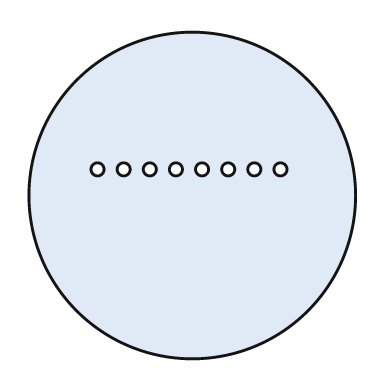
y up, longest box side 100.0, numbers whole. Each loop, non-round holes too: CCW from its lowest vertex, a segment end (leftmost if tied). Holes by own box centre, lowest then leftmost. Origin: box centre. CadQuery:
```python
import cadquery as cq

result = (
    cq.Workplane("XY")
    .moveTo(0.0, 0.0)
    .circle(50.0)
    .moveTo(-29.0, 8.0)
    .circle(2.0)
    .moveTo(-21.0, 8.0)
    .circle(2.0)
    .moveTo(-13.0, 8.0)
    .circle(2.0)
    .moveTo(-5.0, 8.0)
    .circle(2.0)
    .moveTo(3.0, 8.0)
    .circle(2.0)
    .moveTo(11.0, 8.0)
    .circle(2.0)
    .moveTo(19.0, 8.0)
    .circle(2.0)
    .moveTo(27.0, 8.0)
    .circle(2.0)
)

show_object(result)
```